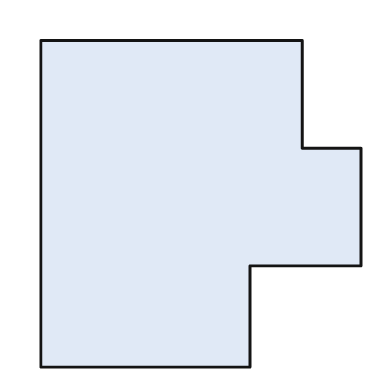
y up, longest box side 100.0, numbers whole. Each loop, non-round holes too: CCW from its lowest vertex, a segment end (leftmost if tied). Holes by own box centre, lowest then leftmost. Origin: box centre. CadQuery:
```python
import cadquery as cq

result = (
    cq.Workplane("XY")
    .moveTo(-49.0, -50.0)
    .lineTo(15.0, -50.0)
    .lineTo(15.0, -19.0)
    .lineTo(49.0, -19.0)
    .lineTo(49.0, 17.0)
    .lineTo(31.0, 17.0)
    .lineTo(31.0, 50.0)
    .lineTo(-49.0, 50.0)
    .close()
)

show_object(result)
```